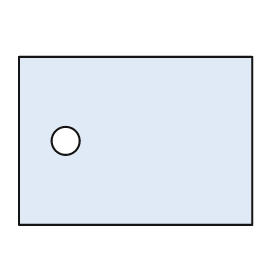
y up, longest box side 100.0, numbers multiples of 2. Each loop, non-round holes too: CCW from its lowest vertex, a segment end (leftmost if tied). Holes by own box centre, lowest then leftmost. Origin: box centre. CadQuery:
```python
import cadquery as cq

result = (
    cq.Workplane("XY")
    .moveTo(-50.0, -36.0)
    .lineTo(50.0, -36.0)
    .lineTo(50.0, 36.0)
    .lineTo(-50.0, 36.0)
    .close()
    .moveTo(-30.0, 0.0)
    .circle(6.0)
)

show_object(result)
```